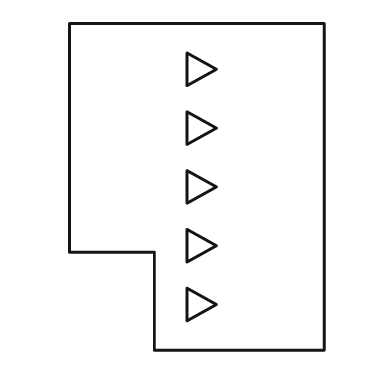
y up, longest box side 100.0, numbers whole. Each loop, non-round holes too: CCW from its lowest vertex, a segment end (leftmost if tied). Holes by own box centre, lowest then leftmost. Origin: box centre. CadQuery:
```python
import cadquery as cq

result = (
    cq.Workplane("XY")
    .moveTo(-13.0, -50.0)
    .lineTo(39.0, -50.0)
    .lineTo(39.0, 50.0)
    .lineTo(-39.0, 50.0)
    .lineTo(-39.0, -20.0)
    .lineTo(-13.0, -20.0)
    .close()
    .moveTo(-3.0, -41.0)
    .lineTo(6.0, -36.0)
    .lineTo(-3.0, -31.0)
    .close()
    .moveTo(-3.0, -23.0)
    .lineTo(6.0, -18.0)
    .lineTo(-3.0, -13.0)
    .close()
    .moveTo(-3.0, -5.0)
    .lineTo(6.0, 0.0)
    .lineTo(-3.0, 5.0)
    .close()
    .moveTo(-3.0, 13.0)
    .lineTo(6.0, 18.0)
    .lineTo(-3.0, 23.0)
    .close()
    .moveTo(-3.0, 31.0)
    .lineTo(6.0, 36.0)
    .lineTo(-3.0, 41.0)
    .close()
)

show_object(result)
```